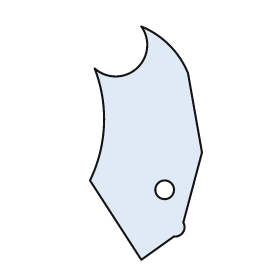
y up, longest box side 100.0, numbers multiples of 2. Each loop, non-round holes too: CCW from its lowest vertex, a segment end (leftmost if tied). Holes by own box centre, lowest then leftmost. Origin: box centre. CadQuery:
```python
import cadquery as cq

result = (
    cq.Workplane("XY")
    .moveTo(-2.0, -50.0)
    .lineTo(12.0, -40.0)
    .threePointArc((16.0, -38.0), (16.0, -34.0))
    .lineTo(24.0, -4.0)
    .lineTo(18.0, 30.0)
    .threePointArc((10.0, 42.0), (-2.0, 50.0))
    .threePointArc((-4.0, 32.0), (-22.0, 32.0))
    .threePointArc((-18.0, 8.0), (-24.0, -16.0))
    .close()
    .moveTo(8.0, -20.0)
    .circle(4.0)
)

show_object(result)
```